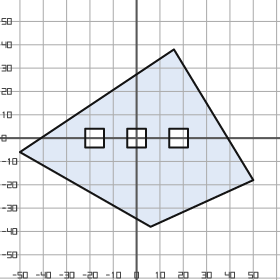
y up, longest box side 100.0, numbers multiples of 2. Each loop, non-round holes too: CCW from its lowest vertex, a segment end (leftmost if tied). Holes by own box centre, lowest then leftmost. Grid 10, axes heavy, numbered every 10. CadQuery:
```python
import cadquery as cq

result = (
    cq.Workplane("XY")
    .moveTo(6.0, -38.0)
    .lineTo(50.0, -18.0)
    .lineTo(16.0, 38.0)
    .lineTo(-50.0, -6.0)
    .close()
    .moveTo(-22.0, -4.0)
    .lineTo(-14.0, -4.0)
    .lineTo(-14.0, 4.0)
    .lineTo(-22.0, 4.0)
    .close()
    .moveTo(-4.0, -4.0)
    .lineTo(4.0, -4.0)
    .lineTo(4.0, 4.0)
    .lineTo(-4.0, 4.0)
    .close()
    .moveTo(14.0, -4.0)
    .lineTo(22.0, -4.0)
    .lineTo(22.0, 4.0)
    .lineTo(14.0, 4.0)
    .close()
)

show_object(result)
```